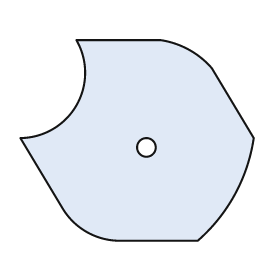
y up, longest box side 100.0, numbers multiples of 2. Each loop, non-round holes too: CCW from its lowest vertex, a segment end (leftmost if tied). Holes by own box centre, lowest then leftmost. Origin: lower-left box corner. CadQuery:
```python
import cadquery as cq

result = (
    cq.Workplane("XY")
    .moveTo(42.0, 0.0)
    .lineTo(76.0, 0.0)
    .threePointArc((92.0, 20.0), (100.0, 44.0))
    .lineTo(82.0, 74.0)
    .threePointArc((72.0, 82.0), (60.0, 86.0))
    .lineTo(24.0, 86.0)
    .threePointArc((24.0, 58.0), (0.0, 44.0))
    .lineTo(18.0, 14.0)
    .threePointArc((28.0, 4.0), (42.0, 0.0))
    .close()
    .moveTo(54.0, 40.0)
    .circle(4.0)
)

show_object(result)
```